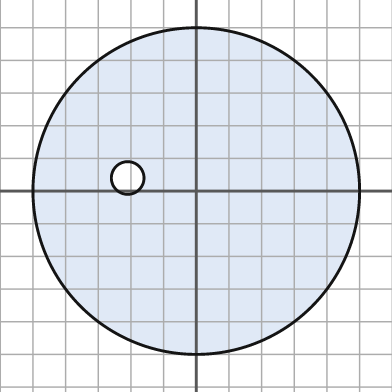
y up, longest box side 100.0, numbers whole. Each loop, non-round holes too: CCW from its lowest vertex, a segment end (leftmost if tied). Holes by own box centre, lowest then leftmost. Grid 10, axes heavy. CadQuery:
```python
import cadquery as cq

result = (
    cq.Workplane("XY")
    .moveTo(0.0, 0.0)
    .circle(50.0)
    .moveTo(-21.0, 4.0)
    .circle(5.0)
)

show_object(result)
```